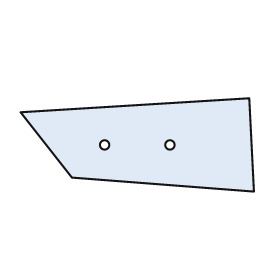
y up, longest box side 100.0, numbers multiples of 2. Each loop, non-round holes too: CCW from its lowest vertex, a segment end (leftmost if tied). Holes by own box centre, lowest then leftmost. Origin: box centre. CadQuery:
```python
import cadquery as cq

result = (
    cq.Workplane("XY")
    .moveTo(50.0, -20.0)
    .lineTo(48.0, 20.0)
    .lineTo(-50.0, 14.0)
    .lineTo(-28.0, -14.0)
    .close()
    .moveTo(-14.0, 0.0)
    .circle(2.0)
    .moveTo(14.0, 0.0)
    .circle(2.0)
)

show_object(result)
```